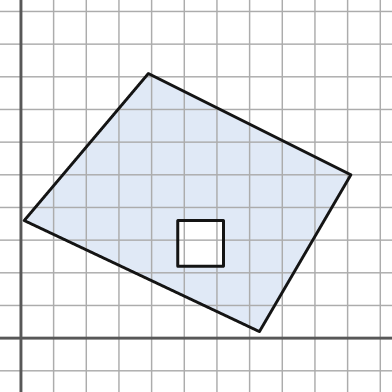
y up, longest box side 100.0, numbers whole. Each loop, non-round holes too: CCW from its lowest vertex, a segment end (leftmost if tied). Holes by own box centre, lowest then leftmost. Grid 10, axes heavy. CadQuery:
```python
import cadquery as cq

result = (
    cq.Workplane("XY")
    .moveTo(73.0, 2.0)
    .lineTo(101.0, 50.0)
    .lineTo(39.0, 81.0)
    .lineTo(1.0, 36.0)
    .close()
    .moveTo(48.0, 22.0)
    .lineTo(62.0, 22.0)
    .lineTo(62.0, 36.0)
    .lineTo(48.0, 36.0)
    .close()
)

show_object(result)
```